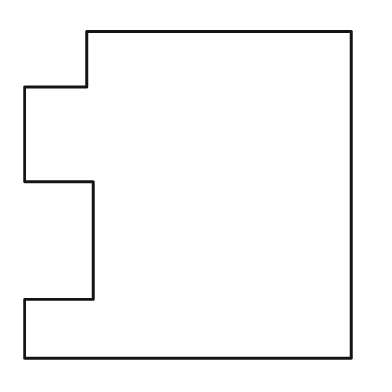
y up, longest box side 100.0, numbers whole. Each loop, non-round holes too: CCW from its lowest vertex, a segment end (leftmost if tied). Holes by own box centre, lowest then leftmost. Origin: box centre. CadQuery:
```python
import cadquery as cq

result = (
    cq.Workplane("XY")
    .moveTo(-50.0, -50.0)
    .lineTo(50.0, -50.0)
    .lineTo(50.0, 50.0)
    .lineTo(-31.0, 50.0)
    .lineTo(-31.0, 33.0)
    .lineTo(-50.0, 33.0)
    .lineTo(-50.0, 4.0)
    .lineTo(-29.0, 4.0)
    .lineTo(-29.0, -32.0)
    .lineTo(-50.0, -32.0)
    .close()
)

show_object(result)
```